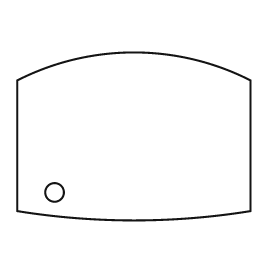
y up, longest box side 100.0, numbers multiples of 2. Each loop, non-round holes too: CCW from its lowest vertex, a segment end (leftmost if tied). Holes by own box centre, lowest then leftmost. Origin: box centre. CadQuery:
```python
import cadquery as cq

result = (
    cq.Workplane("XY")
    .moveTo(-50.0, -32.0)
    .threePointArc((0.0, -36.0), (50.0, -32.0))
    .lineTo(50.0, 24.0)
    .threePointArc((0.0, 36.0), (-50.0, 24.0))
    .close()
    .moveTo(-34.0, -24.0)
    .circle(4.0)
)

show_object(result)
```